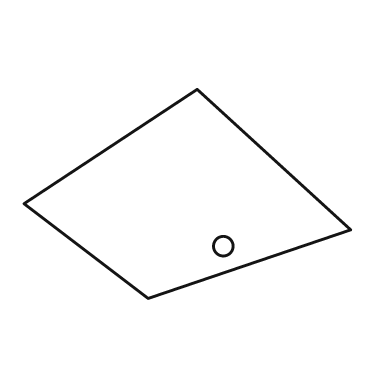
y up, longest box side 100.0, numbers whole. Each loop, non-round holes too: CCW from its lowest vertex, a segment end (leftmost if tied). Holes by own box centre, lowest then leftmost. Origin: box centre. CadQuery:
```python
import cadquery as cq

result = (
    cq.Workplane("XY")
    .moveTo(-12.0, -32.0)
    .lineTo(50.0, -11.0)
    .lineTo(3.0, 32.0)
    .lineTo(-50.0, -3.0)
    .close()
    .moveTo(11.0, -16.0)
    .circle(3.0)
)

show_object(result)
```